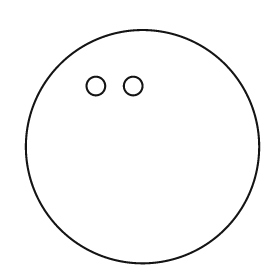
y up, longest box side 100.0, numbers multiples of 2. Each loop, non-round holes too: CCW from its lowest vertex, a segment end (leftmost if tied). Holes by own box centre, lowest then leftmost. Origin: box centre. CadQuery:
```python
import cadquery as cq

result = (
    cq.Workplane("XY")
    .moveTo(0.0, 0.0)
    .circle(50.0)
    .moveTo(-20.0, 26.0)
    .circle(4.0)
    .moveTo(-4.0, 26.0)
    .circle(4.0)
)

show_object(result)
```